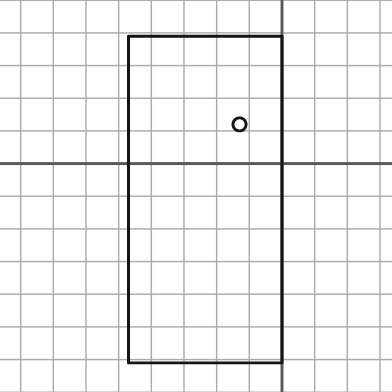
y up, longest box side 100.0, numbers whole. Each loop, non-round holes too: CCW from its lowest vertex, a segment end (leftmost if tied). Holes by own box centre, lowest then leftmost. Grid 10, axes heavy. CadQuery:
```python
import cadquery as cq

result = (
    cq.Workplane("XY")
    .moveTo(-47.0, -61.0)
    .lineTo(0.0, -61.0)
    .lineTo(0.0, 39.0)
    .lineTo(-47.0, 39.0)
    .close()
    .moveTo(-13.0, 12.0)
    .circle(2.0)
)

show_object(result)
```